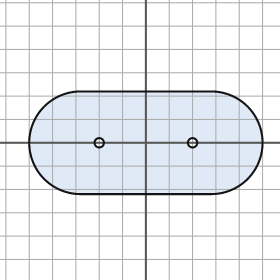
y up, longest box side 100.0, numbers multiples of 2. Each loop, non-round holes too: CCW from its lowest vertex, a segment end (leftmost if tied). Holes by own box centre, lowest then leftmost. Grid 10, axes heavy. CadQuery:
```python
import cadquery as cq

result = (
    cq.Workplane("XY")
    .moveTo(-28.0, -22.0)
    .lineTo(28.0, -22.0)
    .threePointArc((50.0, 0.0), (28.0, 22.0))
    .lineTo(-28.0, 22.0)
    .threePointArc((-50.0, 0.0), (-28.0, -22.0))
    .close()
    .moveTo(-20.0, 0.0)
    .circle(2.0)
    .moveTo(20.0, 0.0)
    .circle(2.0)
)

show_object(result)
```